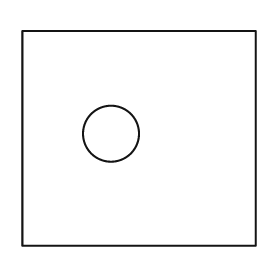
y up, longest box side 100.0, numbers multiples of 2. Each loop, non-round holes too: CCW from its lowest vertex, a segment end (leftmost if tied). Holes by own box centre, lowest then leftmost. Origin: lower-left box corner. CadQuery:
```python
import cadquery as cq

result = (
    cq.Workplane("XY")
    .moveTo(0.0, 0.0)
    .lineTo(100.0, 0.0)
    .lineTo(100.0, 92.0)
    .lineTo(0.0, 92.0)
    .close()
    .moveTo(38.0, 48.0)
    .circle(12.0)
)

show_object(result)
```